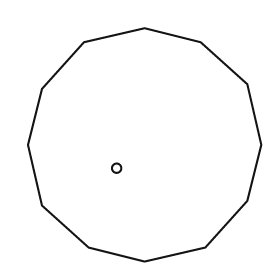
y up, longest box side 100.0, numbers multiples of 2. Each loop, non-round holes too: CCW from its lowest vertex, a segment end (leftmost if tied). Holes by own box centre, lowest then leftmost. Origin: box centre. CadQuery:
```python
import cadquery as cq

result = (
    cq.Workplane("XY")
    .moveTo(0.0, -50.0)
    .lineTo(26.0, -44.0)
    .lineTo(44.0, -24.0)
    .lineTo(50.0, 0.0)
    .lineTo(44.0, 26.0)
    .lineTo(24.0, 44.0)
    .lineTo(0.0, 50.0)
    .lineTo(-26.0, 44.0)
    .lineTo(-44.0, 24.0)
    .lineTo(-50.0, 0.0)
    .lineTo(-44.0, -26.0)
    .lineTo(-24.0, -44.0)
    .close()
    .moveTo(-12.0, -10.0)
    .circle(2.0)
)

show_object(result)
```